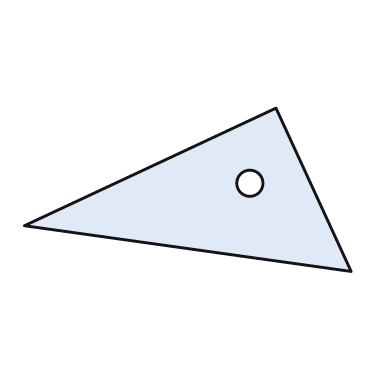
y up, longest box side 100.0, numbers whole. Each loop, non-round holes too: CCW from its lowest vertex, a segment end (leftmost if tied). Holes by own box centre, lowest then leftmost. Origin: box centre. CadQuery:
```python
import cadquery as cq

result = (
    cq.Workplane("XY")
    .moveTo(50.0, -25.0)
    .lineTo(27.0, 25.0)
    .lineTo(-50.0, -11.0)
    .close()
    .moveTo(19.0, 2.0)
    .circle(4.0)
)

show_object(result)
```